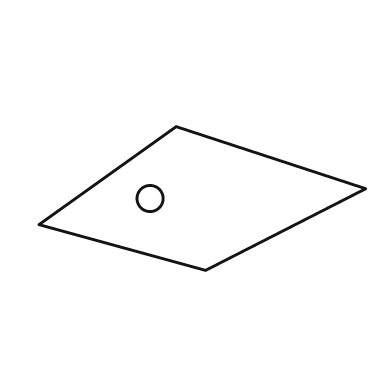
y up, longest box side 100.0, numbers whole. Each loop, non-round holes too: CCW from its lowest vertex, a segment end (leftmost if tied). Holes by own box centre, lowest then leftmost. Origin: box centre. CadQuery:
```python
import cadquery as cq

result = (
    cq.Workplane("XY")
    .moveTo(1.0, -22.0)
    .lineTo(50.0, 3.0)
    .lineTo(-8.0, 22.0)
    .lineTo(-50.0, -8.0)
    .close()
    .moveTo(-16.0, 0.0)
    .circle(4.0)
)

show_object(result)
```